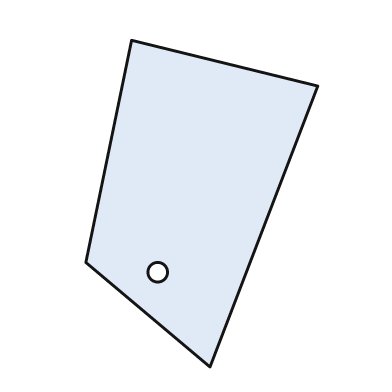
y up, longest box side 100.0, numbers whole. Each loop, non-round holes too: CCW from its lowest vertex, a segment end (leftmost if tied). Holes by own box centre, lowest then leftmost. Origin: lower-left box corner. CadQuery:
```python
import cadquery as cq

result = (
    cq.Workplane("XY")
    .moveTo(38.0, 0.0)
    .lineTo(71.0, 86.0)
    .lineTo(14.0, 100.0)
    .lineTo(0.0, 32.0)
    .close()
    .moveTo(22.0, 29.0)
    .circle(3.0)
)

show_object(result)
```